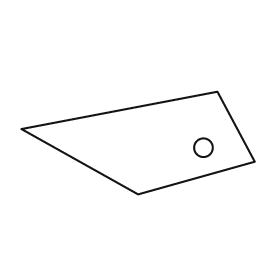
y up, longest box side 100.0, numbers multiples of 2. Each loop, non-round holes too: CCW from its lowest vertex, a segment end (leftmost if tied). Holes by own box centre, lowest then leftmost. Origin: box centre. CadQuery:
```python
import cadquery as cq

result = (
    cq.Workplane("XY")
    .moveTo(0.0, -22.0)
    .lineTo(50.0, -8.0)
    .lineTo(34.0, 22.0)
    .lineTo(-50.0, 6.0)
    .close()
    .moveTo(28.0, -2.0)
    .circle(4.0)
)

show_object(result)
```